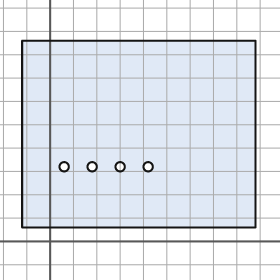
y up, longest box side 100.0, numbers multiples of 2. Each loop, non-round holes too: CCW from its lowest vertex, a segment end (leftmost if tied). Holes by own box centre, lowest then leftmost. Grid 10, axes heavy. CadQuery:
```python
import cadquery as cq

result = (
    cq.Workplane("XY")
    .moveTo(-12.0, 6.0)
    .lineTo(88.0, 6.0)
    .lineTo(88.0, 86.0)
    .lineTo(-12.0, 86.0)
    .close()
    .moveTo(6.0, 32.0)
    .circle(2.0)
    .moveTo(18.0, 32.0)
    .circle(2.0)
    .moveTo(30.0, 32.0)
    .circle(2.0)
    .moveTo(42.0, 32.0)
    .circle(2.0)
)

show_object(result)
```